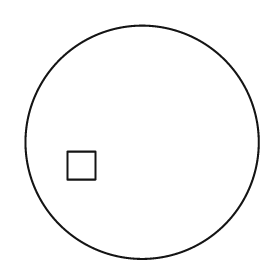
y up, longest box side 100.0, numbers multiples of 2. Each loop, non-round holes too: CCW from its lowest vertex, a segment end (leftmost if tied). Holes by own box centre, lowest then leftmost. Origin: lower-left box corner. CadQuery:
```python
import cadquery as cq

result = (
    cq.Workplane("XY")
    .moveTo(50.0, 50.0)
    .circle(50.0)
    .moveTo(18.0, 34.0)
    .lineTo(30.0, 34.0)
    .lineTo(30.0, 46.0)
    .lineTo(18.0, 46.0)
    .close()
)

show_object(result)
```